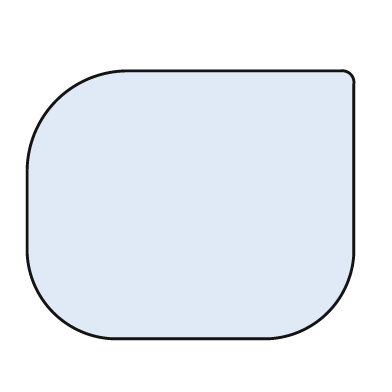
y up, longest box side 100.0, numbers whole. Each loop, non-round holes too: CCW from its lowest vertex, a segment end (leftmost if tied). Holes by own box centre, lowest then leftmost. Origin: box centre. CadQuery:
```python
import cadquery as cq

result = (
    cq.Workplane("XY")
    .moveTo(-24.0, -41.0)
    .lineTo(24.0, -41.0)
    .threePointArc((42.0, -33.0), (50.0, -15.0))
    .lineTo(50.0, 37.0)
    .threePointArc((49.0, 40.0), (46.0, 41.0))
    .lineTo(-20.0, 41.0)
    .threePointArc((-41.0, 32.0), (-50.0, 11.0))
    .lineTo(-50.0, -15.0)
    .threePointArc((-42.0, -33.0), (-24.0, -41.0))
    .close()
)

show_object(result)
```